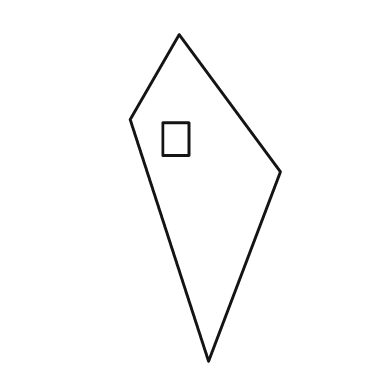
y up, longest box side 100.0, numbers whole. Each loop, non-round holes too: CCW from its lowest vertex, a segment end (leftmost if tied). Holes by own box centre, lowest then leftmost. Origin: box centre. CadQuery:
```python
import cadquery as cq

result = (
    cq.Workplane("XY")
    .moveTo(1.0, -50.0)
    .lineTo(23.0, 8.0)
    .lineTo(-8.0, 50.0)
    .lineTo(-23.0, 24.0)
    .close()
    .moveTo(-13.0, 13.0)
    .lineTo(-5.0, 13.0)
    .lineTo(-5.0, 23.0)
    .lineTo(-13.0, 23.0)
    .close()
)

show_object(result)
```